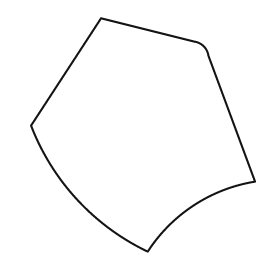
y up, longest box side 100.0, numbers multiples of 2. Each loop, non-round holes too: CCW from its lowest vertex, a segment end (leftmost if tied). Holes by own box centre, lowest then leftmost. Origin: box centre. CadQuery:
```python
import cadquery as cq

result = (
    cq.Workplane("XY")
    .moveTo(2.0, -50.0)
    .threePointArc((22.0, -30.0), (48.0, -20.0))
    .lineTo(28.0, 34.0)
    .threePointArc((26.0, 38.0), (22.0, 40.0))
    .lineTo(-18.0, 50.0)
    .lineTo(-48.0, 4.0)
    .threePointArc((-28.0, -28.0), (2.0, -50.0))
    .close()
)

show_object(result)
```